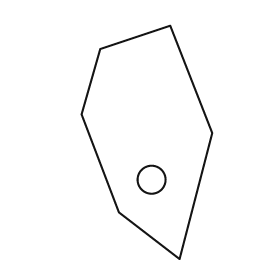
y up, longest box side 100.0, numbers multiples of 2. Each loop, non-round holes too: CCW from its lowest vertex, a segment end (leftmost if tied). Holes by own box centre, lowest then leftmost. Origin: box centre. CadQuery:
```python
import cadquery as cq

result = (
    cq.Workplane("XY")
    .moveTo(14.0, -50.0)
    .lineTo(28.0, 4.0)
    .lineTo(10.0, 50.0)
    .lineTo(-20.0, 40.0)
    .lineTo(-28.0, 12.0)
    .lineTo(-12.0, -30.0)
    .close()
    .moveTo(2.0, -16.0)
    .circle(6.0)
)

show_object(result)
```